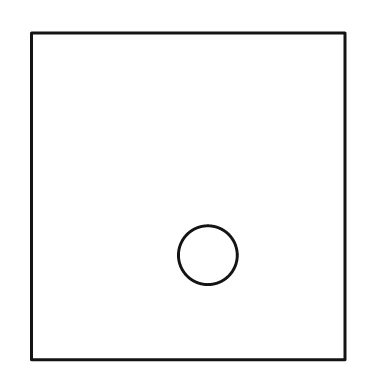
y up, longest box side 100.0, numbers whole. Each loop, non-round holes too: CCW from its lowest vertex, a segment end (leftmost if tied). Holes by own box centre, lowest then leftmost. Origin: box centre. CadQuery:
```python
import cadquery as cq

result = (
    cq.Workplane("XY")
    .moveTo(-48.0, -50.0)
    .lineTo(48.0, -50.0)
    .lineTo(48.0, 50.0)
    .lineTo(-48.0, 50.0)
    .close()
    .moveTo(6.0, -18.0)
    .circle(9.0)
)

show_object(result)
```